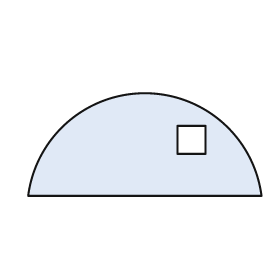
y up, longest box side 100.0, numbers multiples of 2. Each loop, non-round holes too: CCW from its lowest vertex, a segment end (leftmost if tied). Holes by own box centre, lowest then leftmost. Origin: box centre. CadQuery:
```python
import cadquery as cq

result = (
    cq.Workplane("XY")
    .moveTo(-50.0, -22.0)
    .lineTo(50.0, -22.0)
    .threePointArc((0.0, 22.0), (-50.0, -22.0))
    .close()
    .moveTo(14.0, -4.0)
    .lineTo(26.0, -4.0)
    .lineTo(26.0, 8.0)
    .lineTo(14.0, 8.0)
    .close()
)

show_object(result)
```